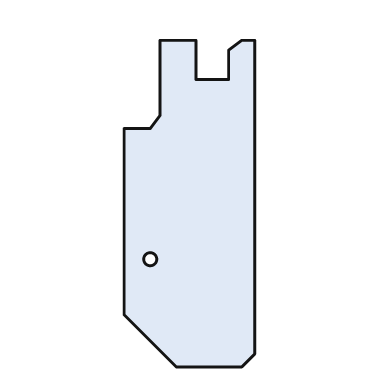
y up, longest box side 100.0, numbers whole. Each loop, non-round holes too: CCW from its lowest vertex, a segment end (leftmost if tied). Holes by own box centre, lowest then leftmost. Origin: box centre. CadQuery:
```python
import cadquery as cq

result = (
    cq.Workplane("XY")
    .moveTo(-4.0, -50.0)
    .lineTo(16.0, -50.0)
    .lineTo(20.0, -46.0)
    .lineTo(20.0, 50.0)
    .lineTo(16.0, 50.0)
    .lineTo(12.0, 47.0)
    .lineTo(12.0, 38.0)
    .lineTo(2.0, 38.0)
    .lineTo(2.0, 50.0)
    .lineTo(-9.0, 50.0)
    .lineTo(-9.0, 27.0)
    .lineTo(-12.0, 23.0)
    .lineTo(-20.0, 23.0)
    .lineTo(-20.0, -34.0)
    .close()
    .moveTo(-12.0, -17.0)
    .circle(2.0)
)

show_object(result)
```